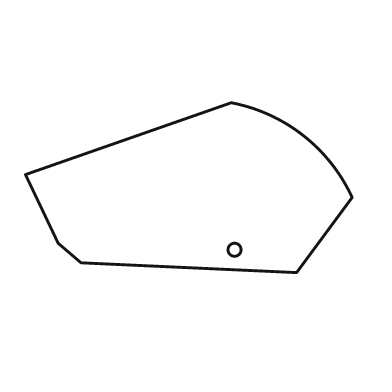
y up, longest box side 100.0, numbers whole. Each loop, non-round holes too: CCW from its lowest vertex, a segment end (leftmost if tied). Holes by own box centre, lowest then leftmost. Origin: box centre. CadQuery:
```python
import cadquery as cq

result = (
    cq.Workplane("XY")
    .moveTo(33.0, -26.0)
    .lineTo(50.0, -3.0)
    .threePointArc((35.0, 16.0), (13.0, 26.0))
    .lineTo(-50.0, 4.0)
    .lineTo(-40.0, -17.0)
    .lineTo(-33.0, -23.0)
    .close()
    .moveTo(14.0, -19.0)
    .circle(2.0)
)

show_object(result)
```